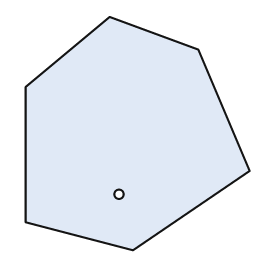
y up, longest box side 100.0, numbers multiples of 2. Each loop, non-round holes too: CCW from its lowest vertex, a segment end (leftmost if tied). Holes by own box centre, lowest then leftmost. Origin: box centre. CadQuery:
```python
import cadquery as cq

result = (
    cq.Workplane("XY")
    .moveTo(-2.0, -50.0)
    .lineTo(48.0, -16.0)
    .lineTo(26.0, 36.0)
    .lineTo(-12.0, 50.0)
    .lineTo(-48.0, 20.0)
    .lineTo(-48.0, -38.0)
    .close()
    .moveTo(-8.0, -26.0)
    .circle(2.0)
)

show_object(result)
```